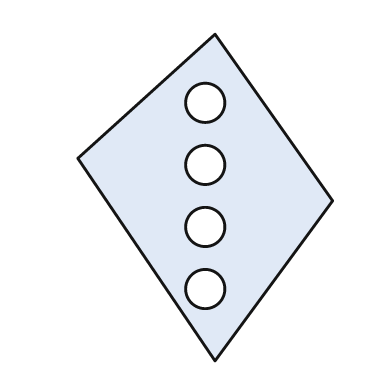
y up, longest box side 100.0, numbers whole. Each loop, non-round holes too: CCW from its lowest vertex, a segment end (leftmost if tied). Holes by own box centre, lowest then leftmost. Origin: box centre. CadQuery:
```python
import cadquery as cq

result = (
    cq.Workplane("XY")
    .moveTo(3.0, -50.0)
    .lineTo(39.0, -1.0)
    .lineTo(3.0, 50.0)
    .lineTo(-39.0, 12.0)
    .close()
    .moveTo(0.0, -28.0)
    .circle(6.0)
    .moveTo(0.0, -9.0)
    .circle(6.0)
    .moveTo(0.0, 10.0)
    .circle(6.0)
    .moveTo(0.0, 29.0)
    .circle(6.0)
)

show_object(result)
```